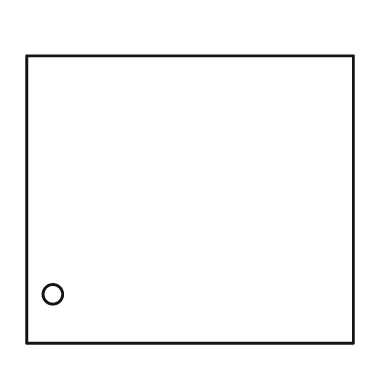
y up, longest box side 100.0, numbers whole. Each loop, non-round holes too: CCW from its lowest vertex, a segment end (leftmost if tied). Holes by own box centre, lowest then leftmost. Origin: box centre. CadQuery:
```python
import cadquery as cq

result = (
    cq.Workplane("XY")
    .moveTo(-50.0, -44.0)
    .lineTo(50.0, -44.0)
    .lineTo(50.0, 44.0)
    .lineTo(-50.0, 44.0)
    .close()
    .moveTo(-42.0, -29.0)
    .circle(3.0)
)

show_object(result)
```